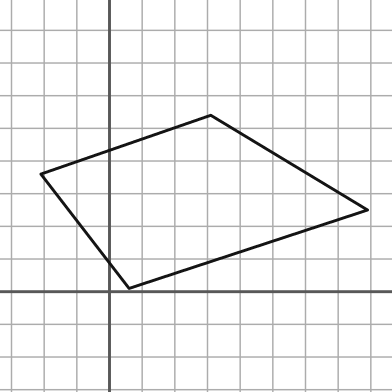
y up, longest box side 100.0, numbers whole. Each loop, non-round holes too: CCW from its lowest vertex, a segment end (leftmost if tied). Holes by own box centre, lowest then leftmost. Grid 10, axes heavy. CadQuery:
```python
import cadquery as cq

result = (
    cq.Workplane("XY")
    .moveTo(6.0, 1.0)
    .lineTo(79.0, 25.0)
    .lineTo(31.0, 54.0)
    .lineTo(-21.0, 36.0)
    .close()
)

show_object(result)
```